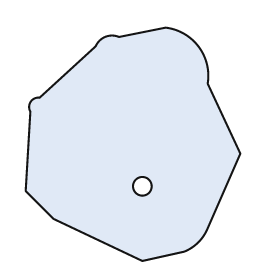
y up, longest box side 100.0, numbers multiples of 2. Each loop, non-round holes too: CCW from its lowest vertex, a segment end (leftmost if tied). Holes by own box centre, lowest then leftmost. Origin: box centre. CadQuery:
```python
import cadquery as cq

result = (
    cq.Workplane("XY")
    .moveTo(4.0, -50.0)
    .lineTo(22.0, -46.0)
    .threePointArc((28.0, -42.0), (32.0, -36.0))
    .lineTo(46.0, -4.0)
    .lineTo(32.0, 26.0)
    .threePointArc((28.0, 42.0), (14.0, 50.0))
    .lineTo(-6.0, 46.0)
    .threePointArc((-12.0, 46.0), (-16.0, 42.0))
    .lineTo(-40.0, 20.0)
    .threePointArc((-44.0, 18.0), (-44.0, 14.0))
    .lineTo(-46.0, -20.0)
    .lineTo(-34.0, -32.0)
    .close()
    .moveTo(4.0, -18.0)
    .circle(4.0)
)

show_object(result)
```